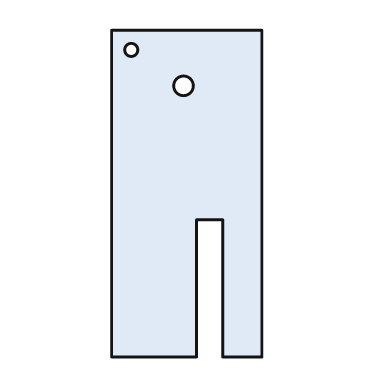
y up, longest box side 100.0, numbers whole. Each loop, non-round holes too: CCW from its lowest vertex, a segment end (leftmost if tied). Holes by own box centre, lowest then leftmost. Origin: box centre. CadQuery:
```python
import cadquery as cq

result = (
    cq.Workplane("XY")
    .moveTo(-23.0, -50.0)
    .lineTo(3.0, -50.0)
    .lineTo(3.0, -8.0)
    .lineTo(11.0, -8.0)
    .lineTo(11.0, -50.0)
    .lineTo(23.0, -50.0)
    .lineTo(23.0, 50.0)
    .lineTo(-23.0, 50.0)
    .close()
    .moveTo(-1.0, 33.0)
    .circle(3.0)
    .moveTo(-17.0, 44.0)
    .circle(2.0)
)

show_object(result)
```